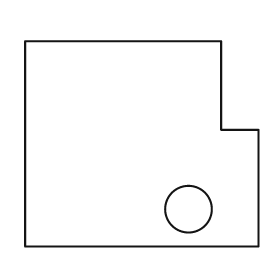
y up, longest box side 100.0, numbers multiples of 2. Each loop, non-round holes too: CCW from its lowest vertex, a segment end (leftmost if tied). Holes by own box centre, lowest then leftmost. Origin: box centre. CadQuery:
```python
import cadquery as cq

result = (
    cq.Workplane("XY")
    .moveTo(-50.0, -44.0)
    .lineTo(50.0, -44.0)
    .lineTo(50.0, 6.0)
    .lineTo(34.0, 6.0)
    .lineTo(34.0, 44.0)
    .lineTo(-50.0, 44.0)
    .close()
    .moveTo(20.0, -28.0)
    .circle(10.0)
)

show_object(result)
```